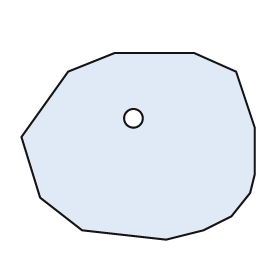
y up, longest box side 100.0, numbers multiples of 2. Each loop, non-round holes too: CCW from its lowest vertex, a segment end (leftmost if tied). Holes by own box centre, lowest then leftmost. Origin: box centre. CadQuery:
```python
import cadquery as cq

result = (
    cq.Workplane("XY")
    .moveTo(12.0, -40.0)
    .lineTo(28.0, -36.0)
    .lineTo(40.0, -30.0)
    .lineTo(48.0, -20.0)
    .lineTo(50.0, -12.0)
    .lineTo(50.0, 8.0)
    .lineTo(42.0, 32.0)
    .lineTo(24.0, 40.0)
    .lineTo(-10.0, 40.0)
    .lineTo(-30.0, 32.0)
    .lineTo(-50.0, 4.0)
    .lineTo(-42.0, -22.0)
    .lineTo(-24.0, -36.0)
    .close()
    .moveTo(-2.0, 12.0)
    .circle(4.0)
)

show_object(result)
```